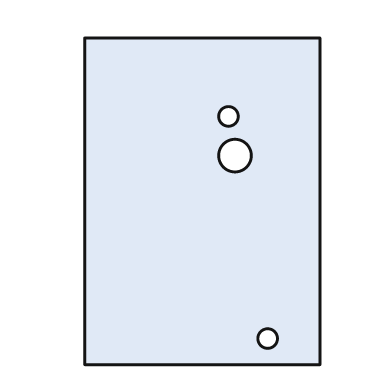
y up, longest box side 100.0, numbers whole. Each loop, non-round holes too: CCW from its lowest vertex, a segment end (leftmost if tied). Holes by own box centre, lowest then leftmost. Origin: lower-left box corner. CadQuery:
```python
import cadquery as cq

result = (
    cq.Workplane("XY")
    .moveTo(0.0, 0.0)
    .lineTo(72.0, 0.0)
    .lineTo(72.0, 100.0)
    .lineTo(0.0, 100.0)
    .close()
    .moveTo(56.0, 8.0)
    .circle(3.0)
    .moveTo(46.0, 64.0)
    .circle(5.0)
    .moveTo(44.0, 76.0)
    .circle(3.0)
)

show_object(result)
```